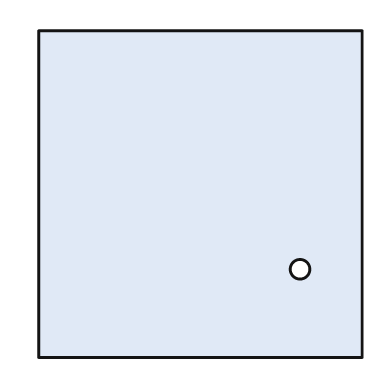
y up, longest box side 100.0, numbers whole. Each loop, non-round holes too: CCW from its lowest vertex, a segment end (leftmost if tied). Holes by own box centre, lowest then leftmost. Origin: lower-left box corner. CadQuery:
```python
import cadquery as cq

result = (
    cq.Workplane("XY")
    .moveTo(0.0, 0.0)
    .lineTo(99.0, 0.0)
    .lineTo(99.0, 100.0)
    .lineTo(0.0, 100.0)
    .close()
    .moveTo(80.0, 27.0)
    .circle(3.0)
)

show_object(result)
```